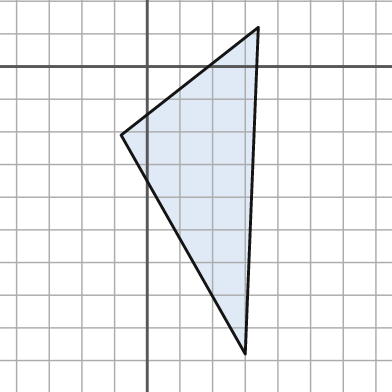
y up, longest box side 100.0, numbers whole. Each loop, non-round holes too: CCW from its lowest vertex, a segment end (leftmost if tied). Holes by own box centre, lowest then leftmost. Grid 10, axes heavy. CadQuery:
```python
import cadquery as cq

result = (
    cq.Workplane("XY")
    .moveTo(30.0, -88.0)
    .lineTo(34.0, 12.0)
    .lineTo(-8.0, -21.0)
    .close()
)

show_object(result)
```